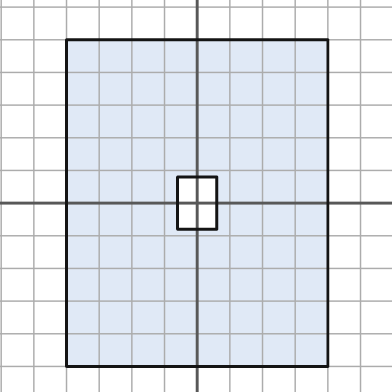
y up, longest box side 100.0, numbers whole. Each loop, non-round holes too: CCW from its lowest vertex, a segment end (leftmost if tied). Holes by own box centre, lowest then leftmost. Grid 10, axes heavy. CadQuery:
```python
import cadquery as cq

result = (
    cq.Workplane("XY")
    .moveTo(-40.0, -50.0)
    .lineTo(40.0, -50.0)
    .lineTo(40.0, 50.0)
    .lineTo(-40.0, 50.0)
    .close()
    .moveTo(-6.0, -8.0)
    .lineTo(6.0, -8.0)
    .lineTo(6.0, 8.0)
    .lineTo(-6.0, 8.0)
    .close()
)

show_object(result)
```